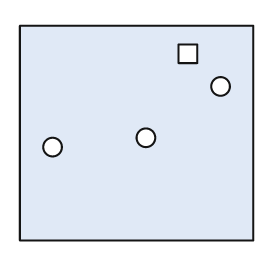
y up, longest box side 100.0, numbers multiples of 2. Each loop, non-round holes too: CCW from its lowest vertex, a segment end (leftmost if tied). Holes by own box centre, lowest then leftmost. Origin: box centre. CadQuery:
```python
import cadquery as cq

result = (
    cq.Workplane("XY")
    .moveTo(-50.0, -46.0)
    .lineTo(50.0, -46.0)
    .lineTo(50.0, 46.0)
    .lineTo(-50.0, 46.0)
    .close()
    .moveTo(-36.0, -6.0)
    .circle(4.0)
    .moveTo(4.0, -2.0)
    .circle(4.0)
    .moveTo(36.0, 20.0)
    .circle(4.0)
    .moveTo(18.0, 30.0)
    .lineTo(26.0, 30.0)
    .lineTo(26.0, 38.0)
    .lineTo(18.0, 38.0)
    .close()
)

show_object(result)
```